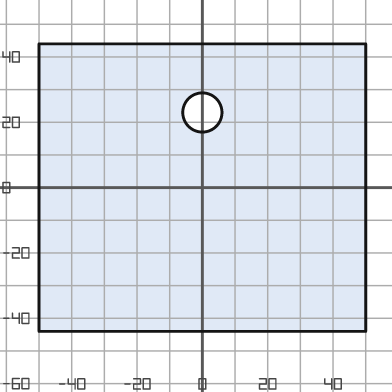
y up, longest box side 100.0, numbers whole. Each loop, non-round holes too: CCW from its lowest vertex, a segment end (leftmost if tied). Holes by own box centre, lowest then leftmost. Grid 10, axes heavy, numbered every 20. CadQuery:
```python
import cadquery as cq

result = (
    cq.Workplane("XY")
    .moveTo(-50.0, -44.0)
    .lineTo(50.0, -44.0)
    .lineTo(50.0, 44.0)
    .lineTo(-50.0, 44.0)
    .close()
    .moveTo(0.0, 23.0)
    .circle(6.0)
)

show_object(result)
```